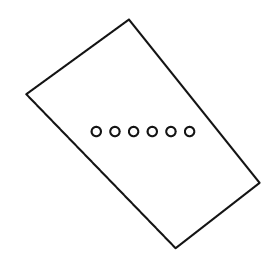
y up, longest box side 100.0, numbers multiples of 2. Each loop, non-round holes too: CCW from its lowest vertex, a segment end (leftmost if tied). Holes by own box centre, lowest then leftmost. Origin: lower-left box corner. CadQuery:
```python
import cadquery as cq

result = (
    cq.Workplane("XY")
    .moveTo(64.0, 0.0)
    .lineTo(100.0, 28.0)
    .lineTo(44.0, 98.0)
    .lineTo(0.0, 66.0)
    .close()
    .moveTo(30.0, 50.0)
    .circle(2.0)
    .moveTo(38.0, 50.0)
    .circle(2.0)
    .moveTo(46.0, 50.0)
    .circle(2.0)
    .moveTo(54.0, 50.0)
    .circle(2.0)
    .moveTo(62.0, 50.0)
    .circle(2.0)
    .moveTo(70.0, 50.0)
    .circle(2.0)
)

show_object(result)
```